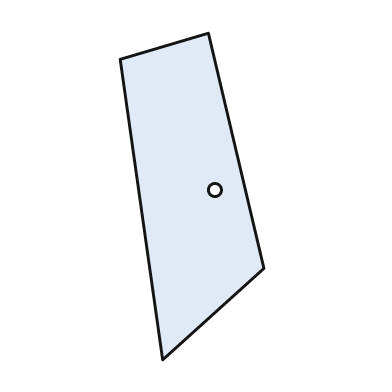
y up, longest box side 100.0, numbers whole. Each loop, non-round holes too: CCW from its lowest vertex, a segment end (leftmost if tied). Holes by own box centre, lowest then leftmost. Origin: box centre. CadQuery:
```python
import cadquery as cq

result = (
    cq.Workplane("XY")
    .moveTo(-9.0, -50.0)
    .lineTo(22.0, -22.0)
    .lineTo(5.0, 50.0)
    .lineTo(-22.0, 42.0)
    .close()
    .moveTo(7.0, 2.0)
    .circle(2.0)
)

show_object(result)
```